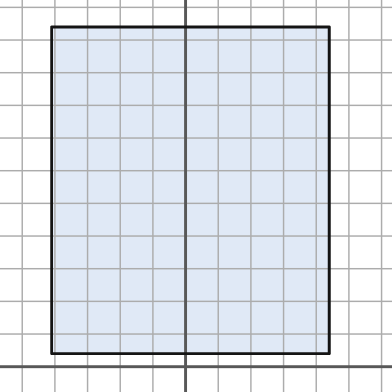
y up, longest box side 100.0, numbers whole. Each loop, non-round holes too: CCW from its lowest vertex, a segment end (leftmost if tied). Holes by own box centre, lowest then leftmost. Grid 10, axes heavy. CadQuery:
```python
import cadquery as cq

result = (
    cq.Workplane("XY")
    .moveTo(-41.0, 4.0)
    .lineTo(44.0, 4.0)
    .lineTo(44.0, 104.0)
    .lineTo(-41.0, 104.0)
    .close()
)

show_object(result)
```